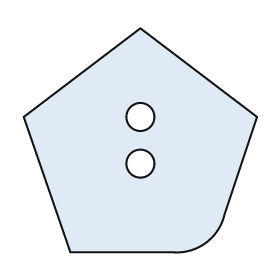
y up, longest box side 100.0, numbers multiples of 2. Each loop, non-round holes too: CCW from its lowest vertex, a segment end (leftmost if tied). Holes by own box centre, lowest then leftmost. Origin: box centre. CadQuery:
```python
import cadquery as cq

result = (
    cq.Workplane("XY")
    .moveTo(-30.0, -48.0)
    .lineTo(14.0, -48.0)
    .threePointArc((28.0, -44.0), (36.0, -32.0))
    .lineTo(50.0, 10.0)
    .lineTo(0.0, 48.0)
    .lineTo(-50.0, 10.0)
    .close()
    .moveTo(0.0, -10.0)
    .circle(6.0)
    .moveTo(0.0, 10.0)
    .circle(6.0)
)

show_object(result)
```